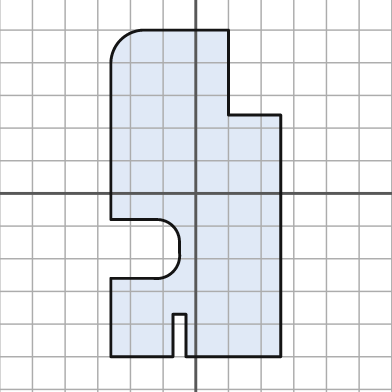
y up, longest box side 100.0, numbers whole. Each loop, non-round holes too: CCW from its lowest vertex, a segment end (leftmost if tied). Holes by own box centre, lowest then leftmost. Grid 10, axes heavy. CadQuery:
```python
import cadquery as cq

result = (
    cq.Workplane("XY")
    .moveTo(-26.0, -50.0)
    .lineTo(-7.0, -50.0)
    .lineTo(-7.0, -37.0)
    .lineTo(-3.0, -37.0)
    .lineTo(-3.0, -50.0)
    .lineTo(26.0, -50.0)
    .lineTo(26.0, 24.0)
    .lineTo(10.0, 24.0)
    .lineTo(10.0, 50.0)
    .lineTo(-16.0, 50.0)
    .threePointArc((-23.0, 47.0), (-26.0, 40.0))
    .lineTo(-26.0, -8.0)
    .lineTo(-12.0, -8.0)
    .threePointArc((-7.0, -10.0), (-5.0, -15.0))
    .lineTo(-5.0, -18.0)
    .threePointArc((-7.0, -24.0), (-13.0, -26.0))
    .lineTo(-26.0, -26.0)
    .close()
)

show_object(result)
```